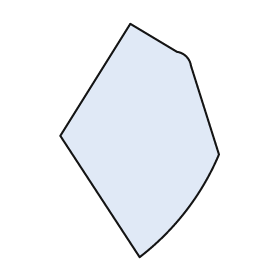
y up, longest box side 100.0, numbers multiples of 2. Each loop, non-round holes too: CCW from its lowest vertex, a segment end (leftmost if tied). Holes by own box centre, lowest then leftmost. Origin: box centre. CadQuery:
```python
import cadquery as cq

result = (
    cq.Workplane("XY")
    .moveTo(0.0, -50.0)
    .threePointArc((20.0, -30.0), (34.0, -6.0))
    .lineTo(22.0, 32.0)
    .threePointArc((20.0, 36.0), (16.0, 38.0))
    .lineTo(-4.0, 50.0)
    .lineTo(-34.0, 2.0)
    .close()
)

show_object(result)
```